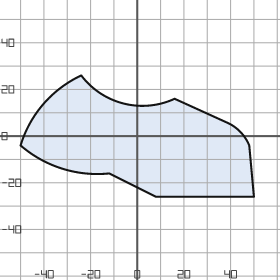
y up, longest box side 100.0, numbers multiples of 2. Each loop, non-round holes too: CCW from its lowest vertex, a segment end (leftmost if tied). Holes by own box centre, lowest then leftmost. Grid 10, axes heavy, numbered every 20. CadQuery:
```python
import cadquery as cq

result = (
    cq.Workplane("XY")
    .moveTo(8.0, -26.0)
    .lineTo(50.0, -26.0)
    .lineTo(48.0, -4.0)
    .threePointArc((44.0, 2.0), (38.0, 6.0))
    .lineTo(16.0, 16.0)
    .threePointArc((-6.0, 14.0), (-24.0, 26.0))
    .threePointArc((-40.0, 14.0), (-50.0, -4.0))
    .threePointArc((-32.0, -14.0), (-12.0, -16.0))
    .close()
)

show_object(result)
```